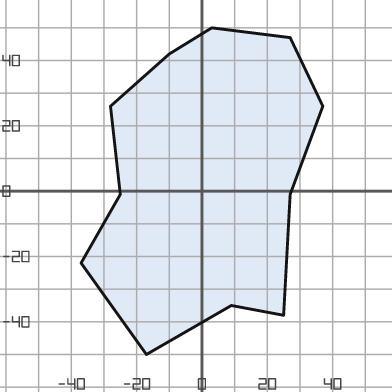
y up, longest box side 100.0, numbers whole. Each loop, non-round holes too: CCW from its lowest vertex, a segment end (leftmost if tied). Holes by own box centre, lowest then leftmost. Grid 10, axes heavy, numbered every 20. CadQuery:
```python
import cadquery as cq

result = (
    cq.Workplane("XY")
    .moveTo(-17.0, -50.0)
    .lineTo(9.0, -35.0)
    .lineTo(25.0, -38.0)
    .lineTo(27.0, -1.0)
    .lineTo(37.0, 26.0)
    .lineTo(27.0, 47.0)
    .lineTo(3.0, 50.0)
    .lineTo(-10.0, 42.0)
    .lineTo(-28.0, 26.0)
    .lineTo(-25.0, -1.0)
    .lineTo(-37.0, -22.0)
    .close()
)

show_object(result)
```